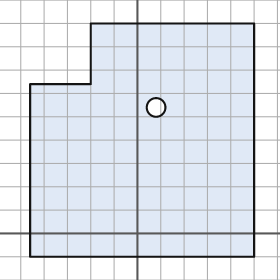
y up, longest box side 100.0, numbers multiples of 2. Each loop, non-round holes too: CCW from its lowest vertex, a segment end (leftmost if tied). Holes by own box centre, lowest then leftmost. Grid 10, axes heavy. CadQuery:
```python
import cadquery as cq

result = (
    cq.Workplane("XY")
    .moveTo(-46.0, -10.0)
    .lineTo(50.0, -10.0)
    .lineTo(50.0, 90.0)
    .lineTo(-20.0, 90.0)
    .lineTo(-20.0, 64.0)
    .lineTo(-46.0, 64.0)
    .close()
    .moveTo(8.0, 54.0)
    .circle(4.0)
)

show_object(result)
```